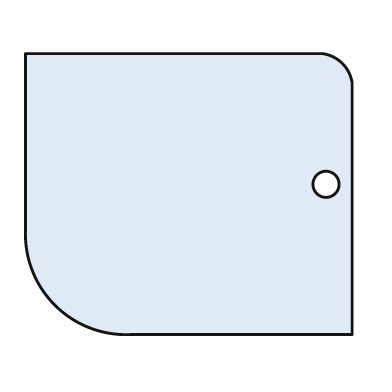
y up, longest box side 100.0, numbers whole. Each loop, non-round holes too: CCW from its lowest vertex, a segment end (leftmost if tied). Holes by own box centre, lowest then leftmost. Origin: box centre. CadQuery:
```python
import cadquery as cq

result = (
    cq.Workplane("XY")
    .moveTo(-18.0, -43.0)
    .lineTo(50.0, -43.0)
    .lineTo(50.0, 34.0)
    .threePointArc((47.0, 40.0), (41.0, 43.0))
    .lineTo(-50.0, 43.0)
    .lineTo(-50.0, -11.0)
    .threePointArc((-41.0, -34.0), (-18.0, -43.0))
    .close()
    .moveTo(42.0, 3.0)
    .circle(4.0)
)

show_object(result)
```